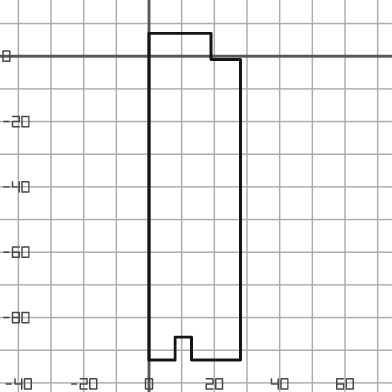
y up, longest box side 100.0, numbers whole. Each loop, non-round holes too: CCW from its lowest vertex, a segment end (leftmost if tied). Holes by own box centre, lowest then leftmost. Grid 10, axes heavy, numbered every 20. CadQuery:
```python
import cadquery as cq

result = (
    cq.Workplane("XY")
    .moveTo(0.0, -93.0)
    .lineTo(8.0, -93.0)
    .lineTo(8.0, -86.0)
    .lineTo(13.0, -86.0)
    .lineTo(13.0, -93.0)
    .lineTo(28.0, -93.0)
    .lineTo(28.0, -1.0)
    .lineTo(19.0, -1.0)
    .lineTo(19.0, 7.0)
    .lineTo(0.0, 7.0)
    .close()
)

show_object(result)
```